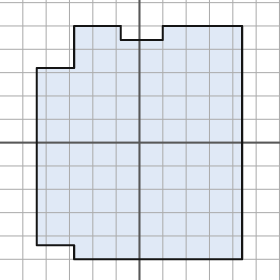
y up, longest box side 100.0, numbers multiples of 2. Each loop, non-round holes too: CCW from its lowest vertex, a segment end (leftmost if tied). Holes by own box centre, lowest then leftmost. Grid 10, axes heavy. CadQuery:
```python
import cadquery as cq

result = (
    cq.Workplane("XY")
    .moveTo(-28.0, -50.0)
    .lineTo(44.0, -50.0)
    .lineTo(44.0, 50.0)
    .lineTo(10.0, 50.0)
    .lineTo(10.0, 44.0)
    .lineTo(-8.0, 44.0)
    .lineTo(-8.0, 50.0)
    .lineTo(-28.0, 50.0)
    .lineTo(-28.0, 32.0)
    .lineTo(-44.0, 32.0)
    .lineTo(-44.0, -44.0)
    .lineTo(-28.0, -44.0)
    .close()
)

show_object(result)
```